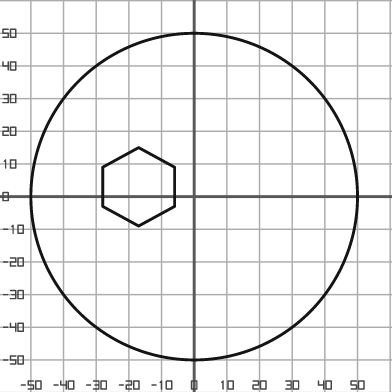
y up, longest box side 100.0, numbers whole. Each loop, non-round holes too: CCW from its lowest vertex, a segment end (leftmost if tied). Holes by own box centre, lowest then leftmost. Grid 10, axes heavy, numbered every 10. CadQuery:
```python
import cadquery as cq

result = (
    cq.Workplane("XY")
    .moveTo(0.0, 0.0)
    .circle(50.0)
    .moveTo(-17.0, -9.0)
    .lineTo(-6.0, -3.0)
    .lineTo(-6.0, 9.0)
    .lineTo(-17.0, 15.0)
    .lineTo(-28.0, 9.0)
    .lineTo(-28.0, -3.0)
    .close()
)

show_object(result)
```